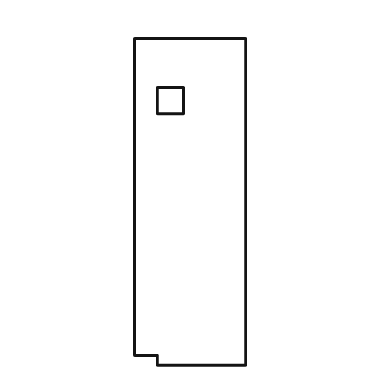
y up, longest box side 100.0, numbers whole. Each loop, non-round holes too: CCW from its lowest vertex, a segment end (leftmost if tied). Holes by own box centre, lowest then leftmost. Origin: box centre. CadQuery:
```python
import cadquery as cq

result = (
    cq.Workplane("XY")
    .moveTo(-10.0, -50.0)
    .lineTo(17.0, -50.0)
    .lineTo(17.0, 50.0)
    .lineTo(-17.0, 50.0)
    .lineTo(-17.0, -47.0)
    .lineTo(-10.0, -47.0)
    .close()
    .moveTo(-10.0, 27.0)
    .lineTo(-2.0, 27.0)
    .lineTo(-2.0, 35.0)
    .lineTo(-10.0, 35.0)
    .close()
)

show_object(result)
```